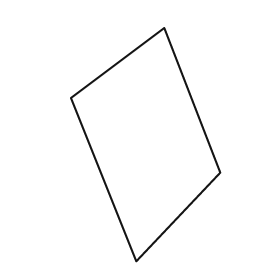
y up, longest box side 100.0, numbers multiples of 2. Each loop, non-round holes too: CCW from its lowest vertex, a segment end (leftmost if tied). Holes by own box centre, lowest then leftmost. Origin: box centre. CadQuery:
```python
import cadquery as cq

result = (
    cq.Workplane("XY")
    .moveTo(-4.0, -50.0)
    .lineTo(32.0, -12.0)
    .lineTo(8.0, 50.0)
    .lineTo(-32.0, 20.0)
    .close()
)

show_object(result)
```